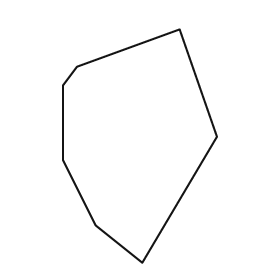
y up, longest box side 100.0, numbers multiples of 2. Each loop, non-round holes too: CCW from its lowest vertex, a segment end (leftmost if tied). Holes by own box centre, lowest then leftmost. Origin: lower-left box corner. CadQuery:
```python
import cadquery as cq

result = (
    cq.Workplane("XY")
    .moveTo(34.0, 0.0)
    .lineTo(66.0, 54.0)
    .lineTo(50.0, 100.0)
    .lineTo(6.0, 84.0)
    .lineTo(0.0, 76.0)
    .lineTo(0.0, 44.0)
    .lineTo(14.0, 16.0)
    .close()
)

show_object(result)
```